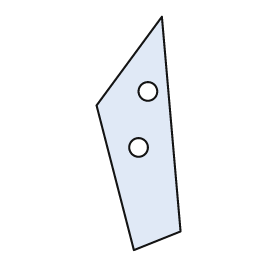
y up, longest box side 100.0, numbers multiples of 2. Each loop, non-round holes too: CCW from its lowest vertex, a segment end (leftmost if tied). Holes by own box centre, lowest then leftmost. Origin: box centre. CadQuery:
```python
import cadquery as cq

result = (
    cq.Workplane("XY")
    .moveTo(-2.0, -50.0)
    .lineTo(18.0, -42.0)
    .lineTo(10.0, 50.0)
    .lineTo(-18.0, 12.0)
    .close()
    .moveTo(0.0, -6.0)
    .circle(4.0)
    .moveTo(4.0, 18.0)
    .circle(4.0)
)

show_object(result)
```